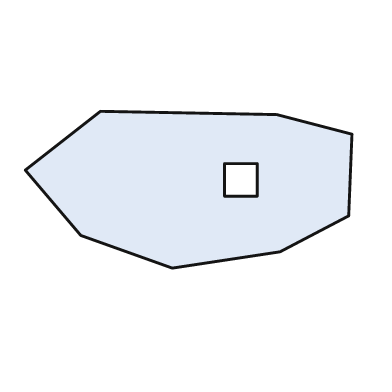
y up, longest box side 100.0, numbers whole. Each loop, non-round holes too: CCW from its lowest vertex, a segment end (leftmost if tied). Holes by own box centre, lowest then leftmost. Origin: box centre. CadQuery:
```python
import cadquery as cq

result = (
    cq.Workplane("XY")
    .moveTo(-5.0, -24.0)
    .lineTo(28.0, -19.0)
    .lineTo(49.0, -8.0)
    .lineTo(50.0, 17.0)
    .lineTo(27.0, 23.0)
    .lineTo(-27.0, 24.0)
    .lineTo(-50.0, 6.0)
    .lineTo(-33.0, -14.0)
    .close()
    .moveTo(11.0, -2.0)
    .lineTo(21.0, -2.0)
    .lineTo(21.0, 8.0)
    .lineTo(11.0, 8.0)
    .close()
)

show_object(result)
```